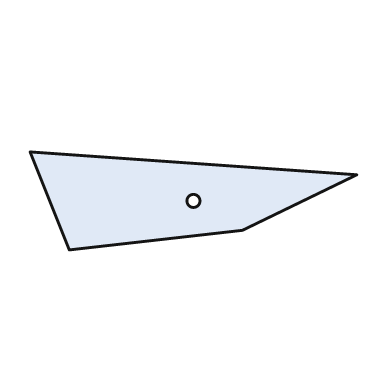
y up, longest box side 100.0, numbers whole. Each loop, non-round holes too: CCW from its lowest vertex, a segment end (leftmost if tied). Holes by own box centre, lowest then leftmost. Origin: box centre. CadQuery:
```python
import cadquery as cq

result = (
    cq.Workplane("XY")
    .moveTo(-38.0, -15.0)
    .lineTo(15.0, -9.0)
    .lineTo(50.0, 8.0)
    .lineTo(-50.0, 15.0)
    .close()
    .moveTo(0.0, 0.0)
    .circle(2.0)
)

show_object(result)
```